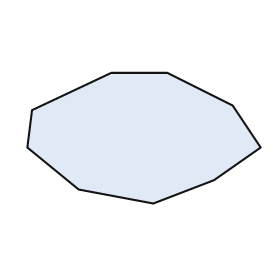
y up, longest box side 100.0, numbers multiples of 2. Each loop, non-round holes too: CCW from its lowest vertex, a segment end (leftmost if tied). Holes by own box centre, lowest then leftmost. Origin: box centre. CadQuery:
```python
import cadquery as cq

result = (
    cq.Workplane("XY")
    .moveTo(4.0, -28.0)
    .lineTo(30.0, -18.0)
    .lineTo(50.0, -4.0)
    .lineTo(38.0, 14.0)
    .lineTo(10.0, 28.0)
    .lineTo(-14.0, 28.0)
    .lineTo(-48.0, 12.0)
    .lineTo(-50.0, -4.0)
    .lineTo(-28.0, -22.0)
    .close()
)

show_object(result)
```